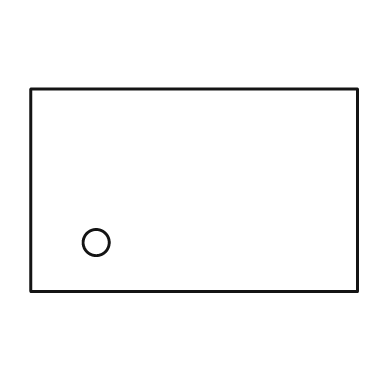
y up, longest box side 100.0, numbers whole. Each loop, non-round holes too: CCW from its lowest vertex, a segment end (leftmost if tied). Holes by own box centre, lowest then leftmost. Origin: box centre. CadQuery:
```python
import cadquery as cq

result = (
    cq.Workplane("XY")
    .moveTo(-50.0, -31.0)
    .lineTo(50.0, -31.0)
    .lineTo(50.0, 31.0)
    .lineTo(-50.0, 31.0)
    .close()
    .moveTo(-30.0, -16.0)
    .circle(4.0)
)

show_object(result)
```